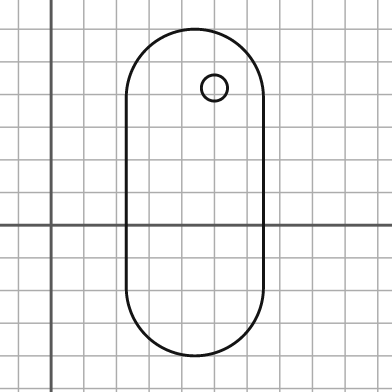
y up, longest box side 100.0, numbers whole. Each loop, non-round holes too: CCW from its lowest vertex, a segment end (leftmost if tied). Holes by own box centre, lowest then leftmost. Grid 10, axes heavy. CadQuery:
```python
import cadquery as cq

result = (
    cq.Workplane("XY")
    .moveTo(23.0, -19.0)
    .threePointArc((44.0, -40.0), (65.0, -19.0))
    .lineTo(65.0, 39.0)
    .threePointArc((44.0, 60.0), (23.0, 39.0))
    .close()
    .moveTo(50.0, 42.0)
    .circle(4.0)
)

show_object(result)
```